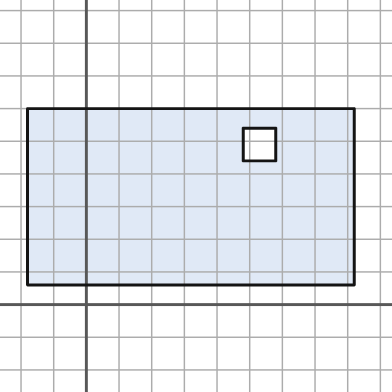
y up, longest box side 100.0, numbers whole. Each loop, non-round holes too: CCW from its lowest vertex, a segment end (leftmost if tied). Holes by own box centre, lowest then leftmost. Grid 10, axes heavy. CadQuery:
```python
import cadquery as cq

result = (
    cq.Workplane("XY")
    .moveTo(-18.0, 6.0)
    .lineTo(82.0, 6.0)
    .lineTo(82.0, 60.0)
    .lineTo(-18.0, 60.0)
    .close()
    .moveTo(48.0, 44.0)
    .lineTo(58.0, 44.0)
    .lineTo(58.0, 54.0)
    .lineTo(48.0, 54.0)
    .close()
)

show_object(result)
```